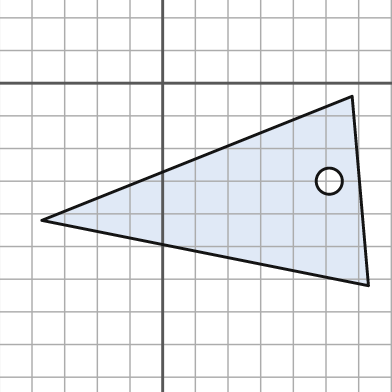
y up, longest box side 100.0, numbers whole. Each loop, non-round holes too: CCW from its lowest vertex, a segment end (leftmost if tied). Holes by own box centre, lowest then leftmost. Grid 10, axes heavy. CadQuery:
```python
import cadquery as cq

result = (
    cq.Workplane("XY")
    .moveTo(63.0, -62.0)
    .lineTo(58.0, -4.0)
    .lineTo(-37.0, -42.0)
    .close()
    .moveTo(51.0, -30.0)
    .circle(4.0)
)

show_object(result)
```